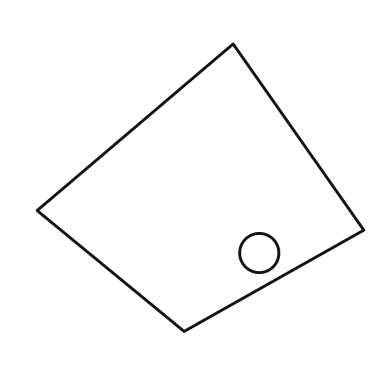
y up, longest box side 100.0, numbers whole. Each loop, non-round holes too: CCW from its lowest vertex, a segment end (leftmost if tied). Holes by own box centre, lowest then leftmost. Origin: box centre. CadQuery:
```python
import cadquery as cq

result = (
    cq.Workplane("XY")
    .moveTo(-5.0, -44.0)
    .lineTo(50.0, -13.0)
    .lineTo(10.0, 44.0)
    .lineTo(-50.0, -7.0)
    .close()
    .moveTo(18.0, -20.0)
    .circle(6.0)
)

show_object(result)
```